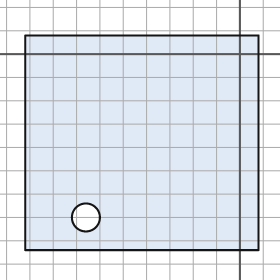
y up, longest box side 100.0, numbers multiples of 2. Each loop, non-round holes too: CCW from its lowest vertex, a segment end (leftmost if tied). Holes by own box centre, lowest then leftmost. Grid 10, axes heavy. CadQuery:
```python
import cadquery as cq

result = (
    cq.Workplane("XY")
    .moveTo(-92.0, -84.0)
    .lineTo(8.0, -84.0)
    .lineTo(8.0, 8.0)
    .lineTo(-92.0, 8.0)
    .close()
    .moveTo(-66.0, -70.0)
    .circle(6.0)
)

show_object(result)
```